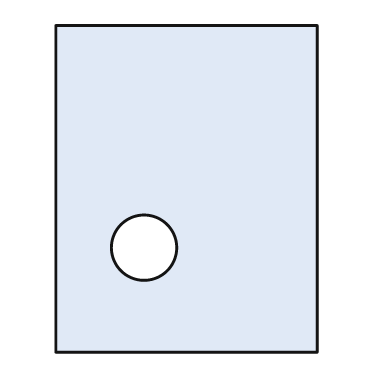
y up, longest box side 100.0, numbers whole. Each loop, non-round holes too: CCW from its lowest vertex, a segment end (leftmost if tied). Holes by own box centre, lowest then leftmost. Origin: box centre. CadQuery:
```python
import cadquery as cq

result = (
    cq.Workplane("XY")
    .moveTo(-40.0, -50.0)
    .lineTo(40.0, -50.0)
    .lineTo(40.0, 50.0)
    .lineTo(-40.0, 50.0)
    .close()
    .moveTo(-13.0, -18.0)
    .circle(10.0)
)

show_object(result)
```